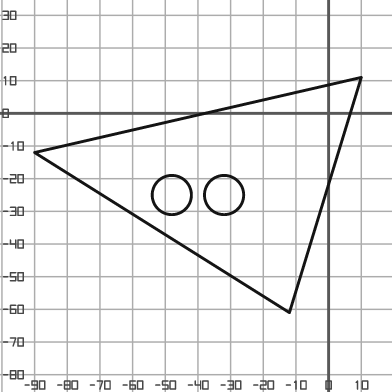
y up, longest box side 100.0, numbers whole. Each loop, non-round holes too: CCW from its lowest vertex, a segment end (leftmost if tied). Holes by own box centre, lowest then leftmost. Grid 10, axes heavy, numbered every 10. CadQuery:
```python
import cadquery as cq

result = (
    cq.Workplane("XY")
    .moveTo(-12.0, -61.0)
    .lineTo(10.0, 11.0)
    .lineTo(-90.0, -12.0)
    .close()
    .moveTo(-48.0, -25.0)
    .circle(6.0)
    .moveTo(-32.0, -25.0)
    .circle(6.0)
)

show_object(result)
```